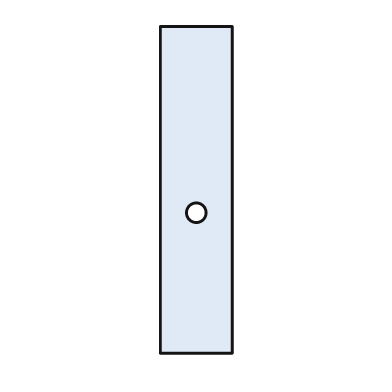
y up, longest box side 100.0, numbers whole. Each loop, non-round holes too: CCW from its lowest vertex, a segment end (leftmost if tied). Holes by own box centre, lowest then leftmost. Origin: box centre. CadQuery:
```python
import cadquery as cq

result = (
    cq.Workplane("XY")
    .moveTo(-11.0, -50.0)
    .lineTo(11.0, -50.0)
    .lineTo(11.0, 50.0)
    .lineTo(-11.0, 50.0)
    .close()
    .moveTo(0.0, -7.0)
    .circle(3.0)
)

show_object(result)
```